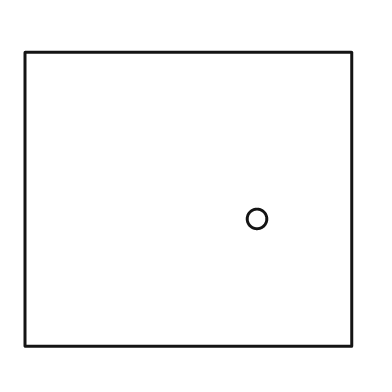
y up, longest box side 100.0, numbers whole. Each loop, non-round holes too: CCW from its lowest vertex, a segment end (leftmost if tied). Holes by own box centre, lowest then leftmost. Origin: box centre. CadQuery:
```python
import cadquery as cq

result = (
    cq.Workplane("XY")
    .moveTo(-50.0, -45.0)
    .lineTo(50.0, -45.0)
    .lineTo(50.0, 45.0)
    .lineTo(-50.0, 45.0)
    .close()
    .moveTo(21.0, -6.0)
    .circle(3.0)
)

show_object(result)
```